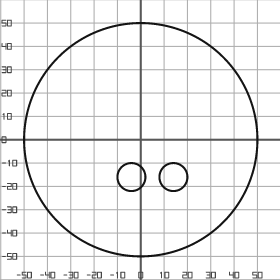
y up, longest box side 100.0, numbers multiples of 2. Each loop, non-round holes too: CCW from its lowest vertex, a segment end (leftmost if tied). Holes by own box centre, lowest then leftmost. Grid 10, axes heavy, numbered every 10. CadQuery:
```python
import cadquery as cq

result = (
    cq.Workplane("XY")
    .moveTo(0.0, 0.0)
    .circle(50.0)
    .moveTo(-4.0, -16.0)
    .circle(6.0)
    .moveTo(14.0, -16.0)
    .circle(6.0)
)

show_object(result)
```